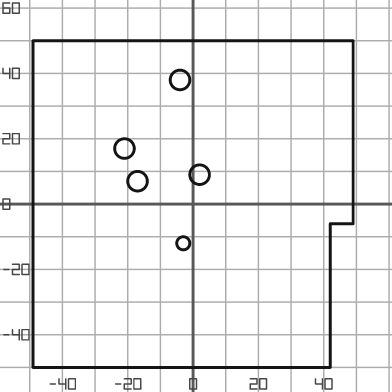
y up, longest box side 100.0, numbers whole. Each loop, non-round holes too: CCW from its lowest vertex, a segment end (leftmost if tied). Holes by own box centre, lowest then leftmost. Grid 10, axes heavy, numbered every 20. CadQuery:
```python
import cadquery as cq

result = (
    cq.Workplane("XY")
    .moveTo(-49.0, -50.0)
    .lineTo(42.0, -50.0)
    .lineTo(42.0, -6.0)
    .lineTo(49.0, -6.0)
    .lineTo(49.0, 50.0)
    .lineTo(-49.0, 50.0)
    .close()
    .moveTo(-3.0, -12.0)
    .circle(2.0)
    .moveTo(-17.0, 7.0)
    .circle(3.0)
    .moveTo(2.0, 9.0)
    .circle(3.0)
    .moveTo(-21.0, 17.0)
    .circle(3.0)
    .moveTo(-4.0, 38.0)
    .circle(3.0)
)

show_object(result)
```